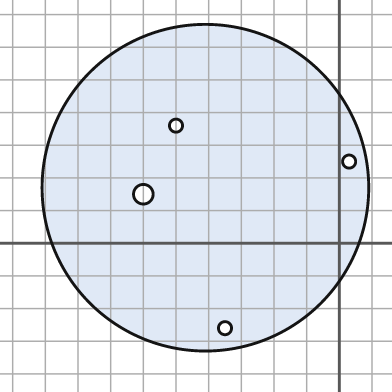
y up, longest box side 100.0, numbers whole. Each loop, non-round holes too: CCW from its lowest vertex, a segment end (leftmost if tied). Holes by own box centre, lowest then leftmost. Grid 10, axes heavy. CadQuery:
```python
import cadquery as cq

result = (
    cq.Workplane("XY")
    .moveTo(-41.0, 17.0)
    .circle(50.0)
    .moveTo(-35.0, -26.0)
    .circle(2.0)
    .moveTo(-60.0, 15.0)
    .circle(3.0)
    .moveTo(3.0, 25.0)
    .circle(2.0)
    .moveTo(-50.0, 36.0)
    .circle(2.0)
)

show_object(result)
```